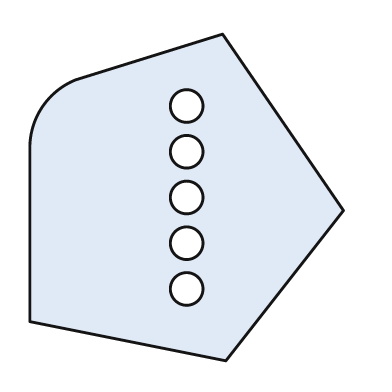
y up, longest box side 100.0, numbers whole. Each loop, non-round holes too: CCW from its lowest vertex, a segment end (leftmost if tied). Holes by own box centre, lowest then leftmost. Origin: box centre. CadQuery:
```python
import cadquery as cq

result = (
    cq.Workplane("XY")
    .moveTo(12.0, -50.0)
    .lineTo(48.0, -4.0)
    .lineTo(11.0, 50.0)
    .lineTo(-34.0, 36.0)
    .threePointArc((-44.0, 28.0), (-48.0, 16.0))
    .lineTo(-48.0, -38.0)
    .close()
    .moveTo(0.0, -28.0)
    .circle(5.0)
    .moveTo(0.0, -14.0)
    .circle(5.0)
    .moveTo(0.0, 0.0)
    .circle(5.0)
    .moveTo(0.0, 14.0)
    .circle(5.0)
    .moveTo(0.0, 28.0)
    .circle(5.0)
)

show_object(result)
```